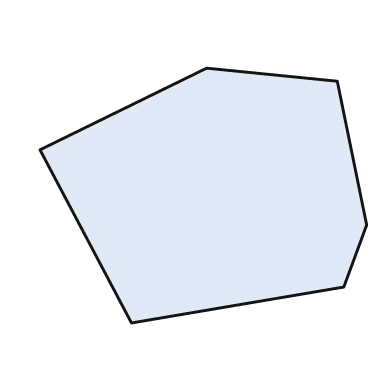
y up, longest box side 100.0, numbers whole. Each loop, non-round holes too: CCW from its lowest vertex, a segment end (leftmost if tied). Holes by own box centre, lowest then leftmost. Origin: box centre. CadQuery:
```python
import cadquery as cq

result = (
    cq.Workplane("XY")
    .moveTo(-22.0, -39.0)
    .lineTo(43.0, -28.0)
    .lineTo(50.0, -9.0)
    .lineTo(41.0, 35.0)
    .lineTo(1.0, 39.0)
    .lineTo(-50.0, 14.0)
    .close()
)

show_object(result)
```